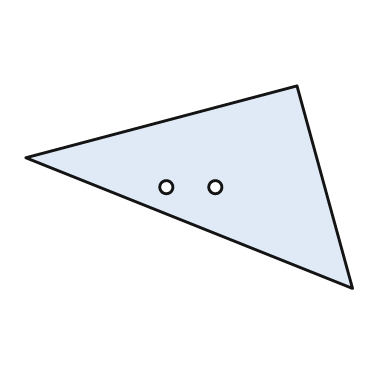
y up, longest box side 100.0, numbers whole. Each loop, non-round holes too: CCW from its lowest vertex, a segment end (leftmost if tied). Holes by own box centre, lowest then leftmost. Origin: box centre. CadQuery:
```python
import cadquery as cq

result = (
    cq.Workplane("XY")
    .moveTo(50.0, -31.0)
    .lineTo(33.0, 31.0)
    .lineTo(-50.0, 9.0)
    .close()
    .moveTo(-7.0, 0.0)
    .circle(2.0)
    .moveTo(8.0, 0.0)
    .circle(2.0)
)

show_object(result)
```